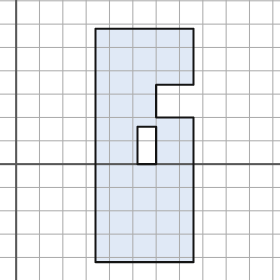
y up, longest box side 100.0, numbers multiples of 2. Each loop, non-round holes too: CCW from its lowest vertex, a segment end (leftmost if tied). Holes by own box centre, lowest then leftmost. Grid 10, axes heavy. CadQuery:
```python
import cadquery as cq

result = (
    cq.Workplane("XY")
    .moveTo(34.0, -42.0)
    .lineTo(76.0, -42.0)
    .lineTo(76.0, 20.0)
    .lineTo(60.0, 20.0)
    .lineTo(60.0, 34.0)
    .lineTo(76.0, 34.0)
    .lineTo(76.0, 58.0)
    .lineTo(34.0, 58.0)
    .close()
    .moveTo(52.0, 0.0)
    .lineTo(60.0, 0.0)
    .lineTo(60.0, 16.0)
    .lineTo(52.0, 16.0)
    .close()
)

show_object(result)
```